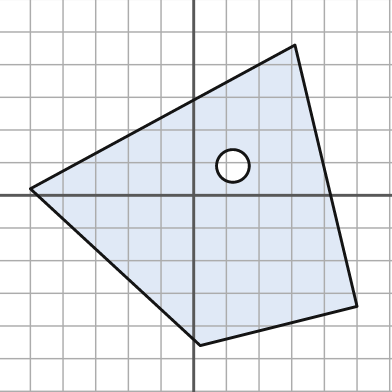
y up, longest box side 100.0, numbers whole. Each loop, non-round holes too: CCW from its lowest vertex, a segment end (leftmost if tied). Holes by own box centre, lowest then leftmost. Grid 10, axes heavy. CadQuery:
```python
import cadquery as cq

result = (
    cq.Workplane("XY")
    .moveTo(2.0, -46.0)
    .lineTo(50.0, -34.0)
    .lineTo(31.0, 46.0)
    .lineTo(-50.0, 2.0)
    .close()
    .moveTo(12.0, 9.0)
    .circle(5.0)
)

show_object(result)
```